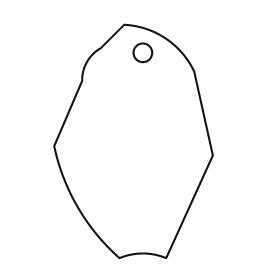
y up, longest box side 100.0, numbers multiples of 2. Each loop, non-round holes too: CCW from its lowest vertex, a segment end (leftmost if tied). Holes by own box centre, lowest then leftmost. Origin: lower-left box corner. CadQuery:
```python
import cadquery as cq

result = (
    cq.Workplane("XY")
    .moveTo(28.0, 0.0)
    .threePointArc((38.0, 2.0), (48.0, 0.0))
    .lineTo(68.0, 44.0)
    .lineTo(60.0, 80.0)
    .threePointArc((48.0, 94.0), (30.0, 100.0))
    .lineTo(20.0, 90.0)
    .threePointArc((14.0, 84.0), (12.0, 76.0))
    .lineTo(0.0, 48.0)
    .threePointArc((10.0, 22.0), (28.0, 0.0))
    .close()
    .moveTo(38.0, 88.0)
    .circle(4.0)
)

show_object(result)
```